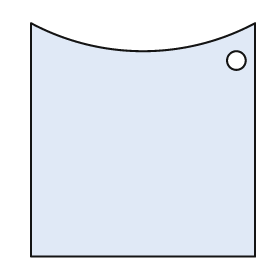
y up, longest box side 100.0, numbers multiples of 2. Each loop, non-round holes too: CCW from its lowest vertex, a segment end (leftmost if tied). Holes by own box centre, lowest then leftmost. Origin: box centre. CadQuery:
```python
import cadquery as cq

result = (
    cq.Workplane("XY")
    .moveTo(-48.0, -50.0)
    .lineTo(48.0, -50.0)
    .lineTo(48.0, 50.0)
    .threePointArc((0.0, 38.0), (-48.0, 50.0))
    .close()
    .moveTo(40.0, 34.0)
    .circle(4.0)
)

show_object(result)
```